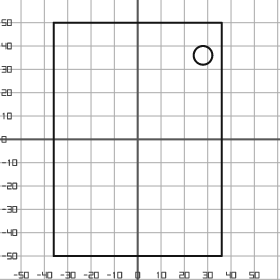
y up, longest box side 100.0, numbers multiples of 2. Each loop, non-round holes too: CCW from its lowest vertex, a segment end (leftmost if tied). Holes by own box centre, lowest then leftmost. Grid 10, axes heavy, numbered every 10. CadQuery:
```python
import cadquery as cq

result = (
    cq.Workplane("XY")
    .moveTo(-36.0, -50.0)
    .lineTo(36.0, -50.0)
    .lineTo(36.0, 50.0)
    .lineTo(-36.0, 50.0)
    .close()
    .moveTo(28.0, 36.0)
    .circle(4.0)
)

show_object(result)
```